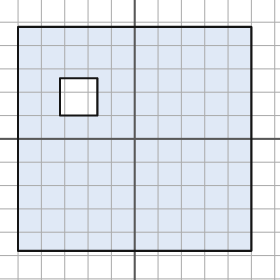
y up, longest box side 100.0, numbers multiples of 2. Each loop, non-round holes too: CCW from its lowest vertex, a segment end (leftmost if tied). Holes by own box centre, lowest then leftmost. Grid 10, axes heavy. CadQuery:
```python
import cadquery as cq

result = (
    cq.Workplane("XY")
    .moveTo(-50.0, -48.0)
    .lineTo(50.0, -48.0)
    .lineTo(50.0, 48.0)
    .lineTo(-50.0, 48.0)
    .close()
    .moveTo(-32.0, 10.0)
    .lineTo(-16.0, 10.0)
    .lineTo(-16.0, 26.0)
    .lineTo(-32.0, 26.0)
    .close()
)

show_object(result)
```